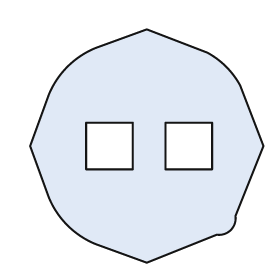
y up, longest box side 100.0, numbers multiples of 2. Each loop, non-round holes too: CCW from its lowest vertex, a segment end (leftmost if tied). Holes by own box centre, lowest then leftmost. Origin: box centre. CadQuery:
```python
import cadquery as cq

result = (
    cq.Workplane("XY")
    .moveTo(0.0, -50.0)
    .lineTo(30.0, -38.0)
    .threePointArc((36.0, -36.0), (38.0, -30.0))
    .lineTo(50.0, 0.0)
    .lineTo(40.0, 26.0)
    .threePointArc((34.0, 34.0), (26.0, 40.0))
    .lineTo(0.0, 50.0)
    .lineTo(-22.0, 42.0)
    .threePointArc((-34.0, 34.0), (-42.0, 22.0))
    .lineTo(-50.0, 0.0)
    .lineTo(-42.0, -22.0)
    .threePointArc((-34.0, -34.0), (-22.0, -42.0))
    .close()
    .moveTo(-26.0, -10.0)
    .lineTo(-6.0, -10.0)
    .lineTo(-6.0, 10.0)
    .lineTo(-26.0, 10.0)
    .close()
    .moveTo(8.0, -10.0)
    .lineTo(28.0, -10.0)
    .lineTo(28.0, 10.0)
    .lineTo(8.0, 10.0)
    .close()
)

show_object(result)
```